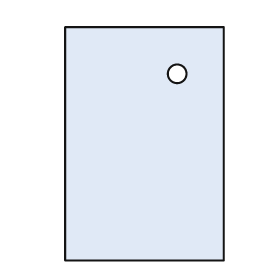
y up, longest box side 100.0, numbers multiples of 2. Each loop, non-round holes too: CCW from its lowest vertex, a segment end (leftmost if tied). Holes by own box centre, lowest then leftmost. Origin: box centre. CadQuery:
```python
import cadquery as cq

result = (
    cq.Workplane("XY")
    .moveTo(-34.0, -50.0)
    .lineTo(34.0, -50.0)
    .lineTo(34.0, 50.0)
    .lineTo(-34.0, 50.0)
    .close()
    .moveTo(14.0, 30.0)
    .circle(4.0)
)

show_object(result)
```